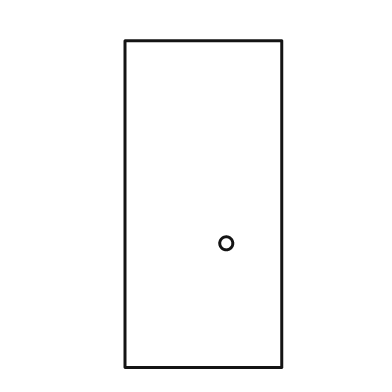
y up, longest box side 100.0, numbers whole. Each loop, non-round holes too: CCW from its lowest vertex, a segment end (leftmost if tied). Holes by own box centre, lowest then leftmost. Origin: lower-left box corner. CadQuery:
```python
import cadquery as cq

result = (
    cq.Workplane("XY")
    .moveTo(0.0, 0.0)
    .lineTo(48.0, 0.0)
    .lineTo(48.0, 100.0)
    .lineTo(0.0, 100.0)
    .close()
    .moveTo(31.0, 38.0)
    .circle(2.0)
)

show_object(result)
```